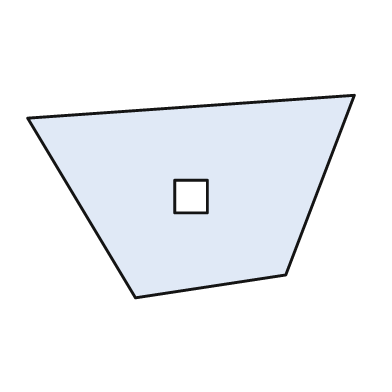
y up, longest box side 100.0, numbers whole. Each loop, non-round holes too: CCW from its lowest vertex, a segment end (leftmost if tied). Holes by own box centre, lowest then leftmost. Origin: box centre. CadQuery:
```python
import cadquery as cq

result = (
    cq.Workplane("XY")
    .moveTo(-17.0, -31.0)
    .lineTo(29.0, -24.0)
    .lineTo(50.0, 31.0)
    .lineTo(-50.0, 24.0)
    .close()
    .moveTo(-5.0, -5.0)
    .lineTo(5.0, -5.0)
    .lineTo(5.0, 5.0)
    .lineTo(-5.0, 5.0)
    .close()
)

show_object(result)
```